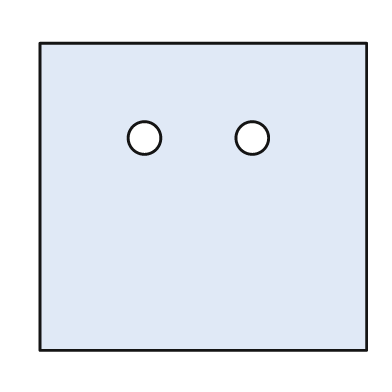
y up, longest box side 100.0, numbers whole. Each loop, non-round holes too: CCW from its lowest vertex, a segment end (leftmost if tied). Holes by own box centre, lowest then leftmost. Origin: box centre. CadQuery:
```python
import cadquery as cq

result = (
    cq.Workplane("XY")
    .moveTo(-50.0, -47.0)
    .lineTo(50.0, -47.0)
    .lineTo(50.0, 47.0)
    .lineTo(-50.0, 47.0)
    .close()
    .moveTo(-18.0, 18.0)
    .circle(5.0)
    .moveTo(15.0, 18.0)
    .circle(5.0)
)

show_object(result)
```